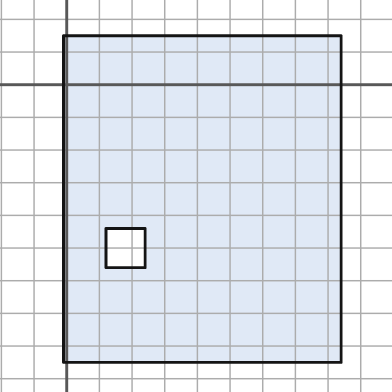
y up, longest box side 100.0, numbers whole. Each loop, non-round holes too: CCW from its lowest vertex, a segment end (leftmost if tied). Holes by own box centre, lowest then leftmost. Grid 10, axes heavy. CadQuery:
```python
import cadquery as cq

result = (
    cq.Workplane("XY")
    .moveTo(-1.0, -85.0)
    .lineTo(84.0, -85.0)
    .lineTo(84.0, 15.0)
    .lineTo(-1.0, 15.0)
    .close()
    .moveTo(12.0, -56.0)
    .lineTo(24.0, -56.0)
    .lineTo(24.0, -44.0)
    .lineTo(12.0, -44.0)
    .close()
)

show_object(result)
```